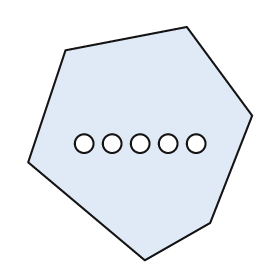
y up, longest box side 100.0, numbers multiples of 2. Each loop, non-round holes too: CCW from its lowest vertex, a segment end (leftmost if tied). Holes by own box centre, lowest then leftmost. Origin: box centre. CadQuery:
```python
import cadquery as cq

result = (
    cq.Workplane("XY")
    .moveTo(2.0, -50.0)
    .lineTo(30.0, -34.0)
    .lineTo(48.0, 12.0)
    .lineTo(20.0, 50.0)
    .lineTo(-32.0, 40.0)
    .lineTo(-48.0, -8.0)
    .close()
    .moveTo(-24.0, 0.0)
    .circle(4.0)
    .moveTo(-12.0, 0.0)
    .circle(4.0)
    .moveTo(0.0, 0.0)
    .circle(4.0)
    .moveTo(12.0, 0.0)
    .circle(4.0)
    .moveTo(24.0, 0.0)
    .circle(4.0)
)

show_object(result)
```